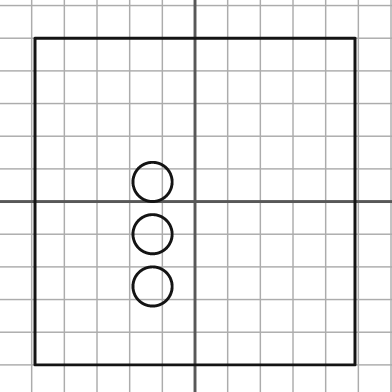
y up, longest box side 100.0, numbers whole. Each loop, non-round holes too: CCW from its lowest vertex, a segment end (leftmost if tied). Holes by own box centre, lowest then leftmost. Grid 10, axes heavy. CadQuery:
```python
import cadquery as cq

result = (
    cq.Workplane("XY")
    .moveTo(-49.0, -50.0)
    .lineTo(49.0, -50.0)
    .lineTo(49.0, 50.0)
    .lineTo(-49.0, 50.0)
    .close()
    .moveTo(-13.0, -26.0)
    .circle(6.0)
    .moveTo(-13.0, -10.0)
    .circle(6.0)
    .moveTo(-13.0, 6.0)
    .circle(6.0)
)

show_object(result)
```